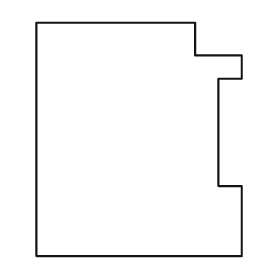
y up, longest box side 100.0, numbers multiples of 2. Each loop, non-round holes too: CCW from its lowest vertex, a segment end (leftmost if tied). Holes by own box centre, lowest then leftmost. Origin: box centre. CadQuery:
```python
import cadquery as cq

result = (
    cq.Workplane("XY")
    .moveTo(-44.0, -50.0)
    .lineTo(44.0, -50.0)
    .lineTo(44.0, -20.0)
    .lineTo(34.0, -20.0)
    .lineTo(34.0, 26.0)
    .lineTo(44.0, 26.0)
    .lineTo(44.0, 36.0)
    .lineTo(24.0, 36.0)
    .lineTo(24.0, 50.0)
    .lineTo(-44.0, 50.0)
    .close()
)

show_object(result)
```